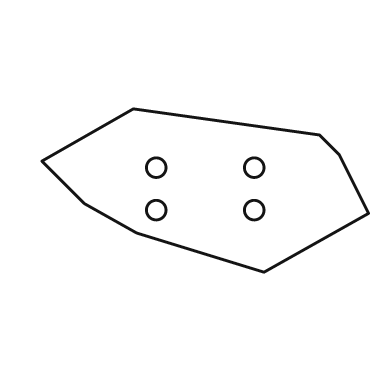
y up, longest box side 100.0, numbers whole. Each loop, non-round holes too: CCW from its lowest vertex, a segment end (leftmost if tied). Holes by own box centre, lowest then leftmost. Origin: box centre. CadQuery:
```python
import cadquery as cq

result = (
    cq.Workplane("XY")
    .moveTo(18.0, -25.0)
    .lineTo(50.0, -7.0)
    .lineTo(41.0, 11.0)
    .lineTo(35.0, 17.0)
    .lineTo(-22.0, 25.0)
    .lineTo(-50.0, 9.0)
    .lineTo(-37.0, -4.0)
    .lineTo(-21.0, -13.0)
    .close()
    .moveTo(-15.0, -6.0)
    .circle(3.0)
    .moveTo(15.0, -6.0)
    .circle(3.0)
    .moveTo(-15.0, 7.0)
    .circle(3.0)
    .moveTo(15.0, 7.0)
    .circle(3.0)
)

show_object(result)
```